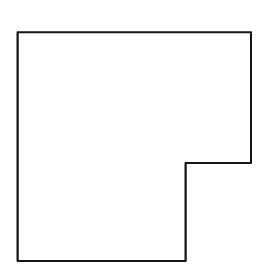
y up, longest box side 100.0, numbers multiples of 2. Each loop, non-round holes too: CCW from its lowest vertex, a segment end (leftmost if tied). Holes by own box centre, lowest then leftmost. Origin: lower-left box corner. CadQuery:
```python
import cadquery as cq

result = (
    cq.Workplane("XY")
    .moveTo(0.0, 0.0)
    .lineTo(72.0, 0.0)
    .lineTo(72.0, 42.0)
    .lineTo(100.0, 42.0)
    .lineTo(100.0, 98.0)
    .lineTo(0.0, 98.0)
    .close()
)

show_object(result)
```